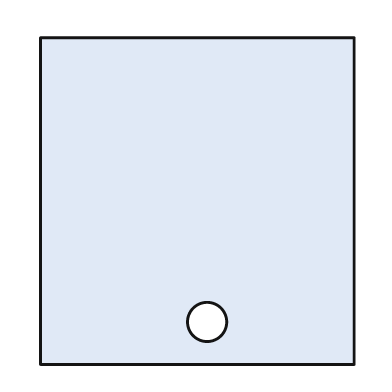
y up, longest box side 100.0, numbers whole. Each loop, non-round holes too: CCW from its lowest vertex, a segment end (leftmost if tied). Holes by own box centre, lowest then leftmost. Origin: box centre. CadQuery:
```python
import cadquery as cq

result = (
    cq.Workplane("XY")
    .moveTo(-48.0, -50.0)
    .lineTo(48.0, -50.0)
    .lineTo(48.0, 50.0)
    .lineTo(-48.0, 50.0)
    .close()
    .moveTo(3.0, -37.0)
    .circle(6.0)
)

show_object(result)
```